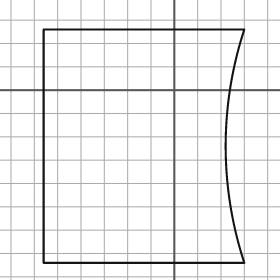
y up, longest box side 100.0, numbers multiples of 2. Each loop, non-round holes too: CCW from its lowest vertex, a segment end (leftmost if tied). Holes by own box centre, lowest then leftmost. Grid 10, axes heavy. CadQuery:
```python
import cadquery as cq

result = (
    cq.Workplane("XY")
    .moveTo(-56.0, -74.0)
    .lineTo(30.0, -74.0)
    .threePointArc((22.0, -24.0), (30.0, 26.0))
    .lineTo(-56.0, 26.0)
    .close()
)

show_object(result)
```